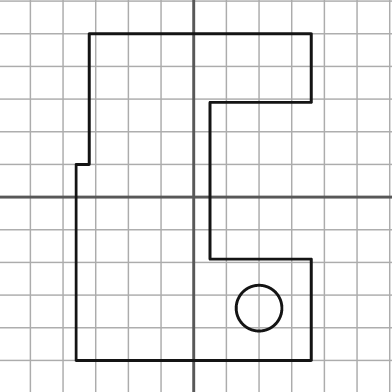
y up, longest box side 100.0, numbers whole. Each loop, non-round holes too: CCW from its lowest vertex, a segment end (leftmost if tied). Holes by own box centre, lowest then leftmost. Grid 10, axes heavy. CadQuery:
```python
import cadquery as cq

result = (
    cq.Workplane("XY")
    .moveTo(-36.0, -50.0)
    .lineTo(36.0, -50.0)
    .lineTo(36.0, -19.0)
    .lineTo(5.0, -19.0)
    .lineTo(5.0, 29.0)
    .lineTo(36.0, 29.0)
    .lineTo(36.0, 50.0)
    .lineTo(-32.0, 50.0)
    .lineTo(-32.0, 10.0)
    .lineTo(-36.0, 10.0)
    .close()
    .moveTo(20.0, -34.0)
    .circle(7.0)
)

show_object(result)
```